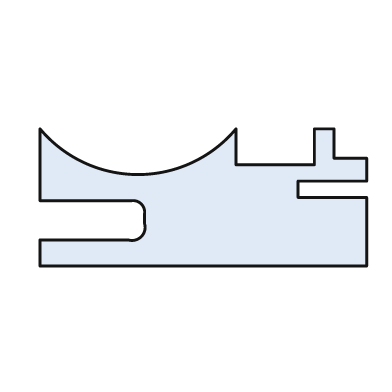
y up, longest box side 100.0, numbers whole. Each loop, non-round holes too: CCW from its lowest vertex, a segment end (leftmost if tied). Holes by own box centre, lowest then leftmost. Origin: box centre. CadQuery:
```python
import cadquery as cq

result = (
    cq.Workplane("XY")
    .moveTo(-50.0, -21.0)
    .lineTo(50.0, -21.0)
    .lineTo(50.0, 0.0)
    .lineTo(29.0, 0.0)
    .lineTo(29.0, 5.0)
    .lineTo(50.0, 5.0)
    .lineTo(50.0, 12.0)
    .lineTo(40.0, 12.0)
    .lineTo(40.0, 21.0)
    .lineTo(34.0, 21.0)
    .lineTo(34.0, 10.0)
    .lineTo(10.0, 10.0)
    .lineTo(10.0, 21.0)
    .threePointArc((-20.0, 7.0), (-50.0, 21.0))
    .lineTo(-50.0, -1.0)
    .lineTo(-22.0, -1.0)
    .threePointArc((-19.0, -2.0), (-18.0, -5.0))
    .lineTo(-18.0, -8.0)
    .threePointArc((-19.0, -12.0), (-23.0, -13.0))
    .lineTo(-50.0, -13.0)
    .close()
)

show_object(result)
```